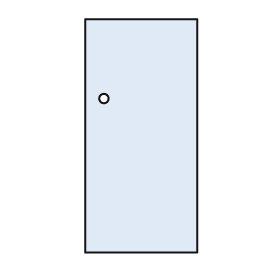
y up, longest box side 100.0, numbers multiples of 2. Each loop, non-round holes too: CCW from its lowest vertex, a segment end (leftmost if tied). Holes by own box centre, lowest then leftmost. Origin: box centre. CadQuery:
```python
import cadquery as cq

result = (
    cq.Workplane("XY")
    .moveTo(-24.0, -50.0)
    .lineTo(24.0, -50.0)
    .lineTo(24.0, 50.0)
    .lineTo(-24.0, 50.0)
    .close()
    .moveTo(-16.0, 16.0)
    .circle(2.0)
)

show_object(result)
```